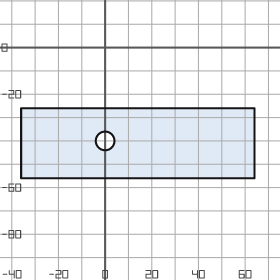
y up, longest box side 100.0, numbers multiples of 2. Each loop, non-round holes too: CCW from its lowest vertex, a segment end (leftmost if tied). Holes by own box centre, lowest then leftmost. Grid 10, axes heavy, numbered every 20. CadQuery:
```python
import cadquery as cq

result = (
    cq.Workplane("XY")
    .moveTo(-36.0, -56.0)
    .lineTo(64.0, -56.0)
    .lineTo(64.0, -26.0)
    .lineTo(-36.0, -26.0)
    .close()
    .moveTo(0.0, -40.0)
    .circle(4.0)
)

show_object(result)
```